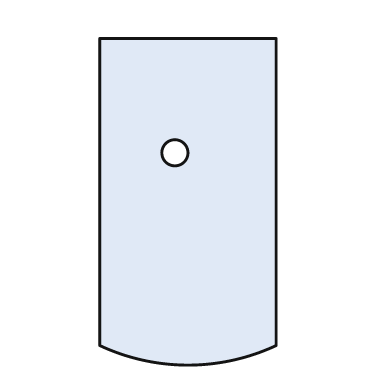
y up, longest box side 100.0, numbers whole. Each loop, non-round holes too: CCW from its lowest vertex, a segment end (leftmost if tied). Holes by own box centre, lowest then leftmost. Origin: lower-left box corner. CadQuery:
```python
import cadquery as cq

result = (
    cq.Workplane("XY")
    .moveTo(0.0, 6.0)
    .threePointArc((27.0, 0.0), (54.0, 6.0))
    .lineTo(54.0, 100.0)
    .lineTo(0.0, 100.0)
    .close()
    .moveTo(23.0, 65.0)
    .circle(4.0)
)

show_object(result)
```